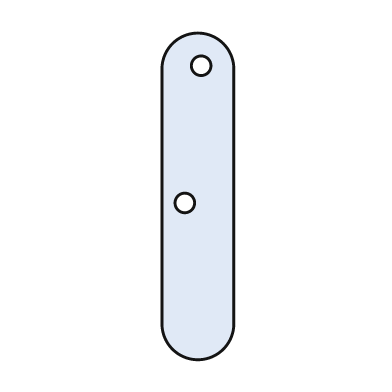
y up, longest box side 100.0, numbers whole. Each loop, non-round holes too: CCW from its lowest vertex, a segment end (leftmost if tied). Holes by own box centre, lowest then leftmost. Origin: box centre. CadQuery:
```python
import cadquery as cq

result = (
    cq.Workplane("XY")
    .moveTo(-11.0, -39.0)
    .threePointArc((0.0, -50.0), (11.0, -39.0))
    .lineTo(11.0, 39.0)
    .threePointArc((0.0, 50.0), (-11.0, 39.0))
    .close()
    .moveTo(-4.0, -2.0)
    .circle(3.0)
    .moveTo(1.0, 40.0)
    .circle(3.0)
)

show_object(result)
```